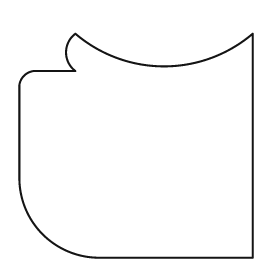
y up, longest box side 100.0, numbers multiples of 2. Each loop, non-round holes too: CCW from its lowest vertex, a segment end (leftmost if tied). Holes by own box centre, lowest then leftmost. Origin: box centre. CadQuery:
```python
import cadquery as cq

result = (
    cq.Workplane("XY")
    .moveTo(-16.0, -48.0)
    .lineTo(50.0, -48.0)
    .lineTo(50.0, 48.0)
    .threePointArc((12.0, 34.0), (-26.0, 48.0))
    .threePointArc((-30.0, 40.0), (-26.0, 32.0))
    .lineTo(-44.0, 32.0)
    .threePointArc((-48.0, 30.0), (-50.0, 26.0))
    .lineTo(-50.0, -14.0)
    .threePointArc((-40.0, -38.0), (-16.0, -48.0))
    .close()
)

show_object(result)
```